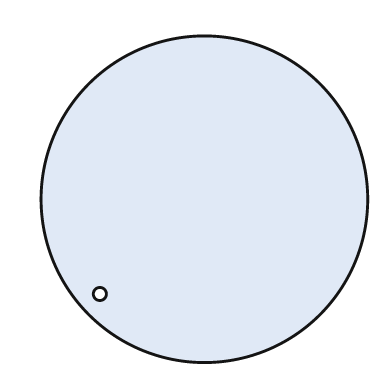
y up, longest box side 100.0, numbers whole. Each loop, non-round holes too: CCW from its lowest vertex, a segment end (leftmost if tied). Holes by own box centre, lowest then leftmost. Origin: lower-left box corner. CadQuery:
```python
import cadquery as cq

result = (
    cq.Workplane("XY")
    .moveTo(50.0, 50.0)
    .circle(50.0)
    .moveTo(18.0, 21.0)
    .circle(2.0)
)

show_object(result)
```